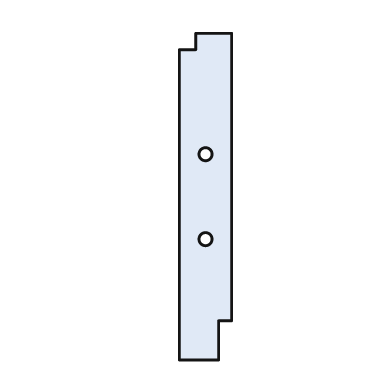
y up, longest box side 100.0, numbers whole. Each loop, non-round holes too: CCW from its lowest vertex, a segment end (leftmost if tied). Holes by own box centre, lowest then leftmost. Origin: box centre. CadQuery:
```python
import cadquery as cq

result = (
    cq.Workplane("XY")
    .moveTo(-8.0, -50.0)
    .lineTo(4.0, -50.0)
    .lineTo(4.0, -38.0)
    .lineTo(8.0, -38.0)
    .lineTo(8.0, 50.0)
    .lineTo(-3.0, 50.0)
    .lineTo(-3.0, 45.0)
    .lineTo(-8.0, 45.0)
    .close()
    .moveTo(0.0, -13.0)
    .circle(2.0)
    .moveTo(0.0, 13.0)
    .circle(2.0)
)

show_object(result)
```